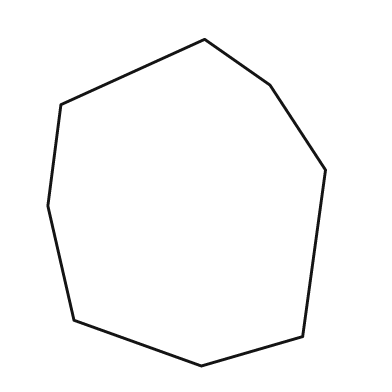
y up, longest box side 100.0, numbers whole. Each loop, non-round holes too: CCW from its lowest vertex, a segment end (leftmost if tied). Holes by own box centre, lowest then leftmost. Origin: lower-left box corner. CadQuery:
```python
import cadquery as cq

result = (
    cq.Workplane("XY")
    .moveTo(47.0, 0.0)
    .lineTo(78.0, 9.0)
    .lineTo(85.0, 60.0)
    .lineTo(68.0, 86.0)
    .lineTo(48.0, 100.0)
    .lineTo(4.0, 80.0)
    .lineTo(0.0, 49.0)
    .lineTo(8.0, 14.0)
    .close()
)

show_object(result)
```